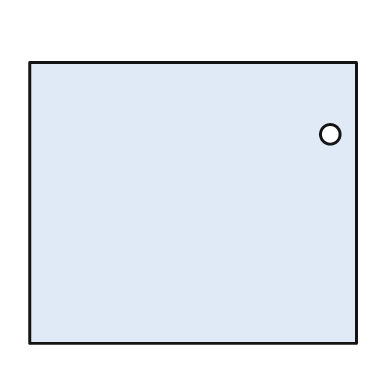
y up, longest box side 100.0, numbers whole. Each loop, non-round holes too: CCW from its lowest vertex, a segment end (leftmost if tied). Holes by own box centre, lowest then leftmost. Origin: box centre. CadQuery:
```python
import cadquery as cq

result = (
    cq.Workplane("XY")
    .moveTo(-50.0, -43.0)
    .lineTo(50.0, -43.0)
    .lineTo(50.0, 43.0)
    .lineTo(-50.0, 43.0)
    .close()
    .moveTo(42.0, 21.0)
    .circle(3.0)
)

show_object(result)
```